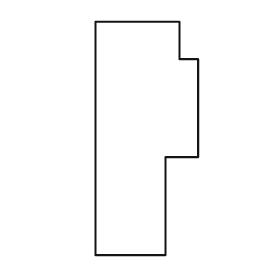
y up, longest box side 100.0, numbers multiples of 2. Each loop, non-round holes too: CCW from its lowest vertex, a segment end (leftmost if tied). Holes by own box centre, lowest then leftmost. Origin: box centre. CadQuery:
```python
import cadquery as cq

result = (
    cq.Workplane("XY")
    .moveTo(-22.0, -50.0)
    .lineTo(8.0, -50.0)
    .lineTo(8.0, -8.0)
    .lineTo(22.0, -8.0)
    .lineTo(22.0, 34.0)
    .lineTo(14.0, 34.0)
    .lineTo(14.0, 50.0)
    .lineTo(-22.0, 50.0)
    .close()
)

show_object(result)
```